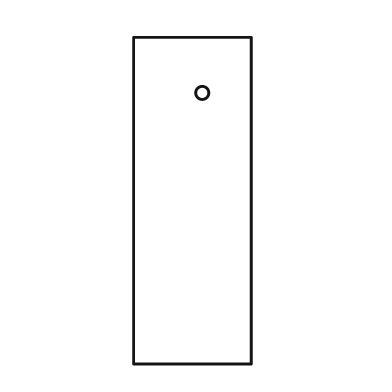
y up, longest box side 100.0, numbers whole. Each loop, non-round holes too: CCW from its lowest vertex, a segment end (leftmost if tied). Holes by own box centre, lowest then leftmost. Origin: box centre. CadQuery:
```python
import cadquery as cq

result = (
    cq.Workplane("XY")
    .moveTo(-18.0, -50.0)
    .lineTo(18.0, -50.0)
    .lineTo(18.0, 50.0)
    .lineTo(-18.0, 50.0)
    .close()
    .moveTo(3.0, 33.0)
    .circle(2.0)
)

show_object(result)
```